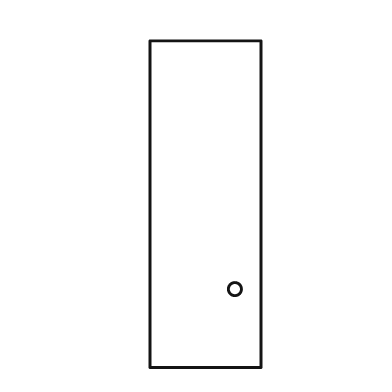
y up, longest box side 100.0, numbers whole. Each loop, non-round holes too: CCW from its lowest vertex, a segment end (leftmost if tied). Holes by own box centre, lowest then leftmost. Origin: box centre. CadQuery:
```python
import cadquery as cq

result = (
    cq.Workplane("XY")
    .moveTo(-17.0, -50.0)
    .lineTo(17.0, -50.0)
    .lineTo(17.0, 50.0)
    .lineTo(-17.0, 50.0)
    .close()
    .moveTo(9.0, -26.0)
    .circle(2.0)
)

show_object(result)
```